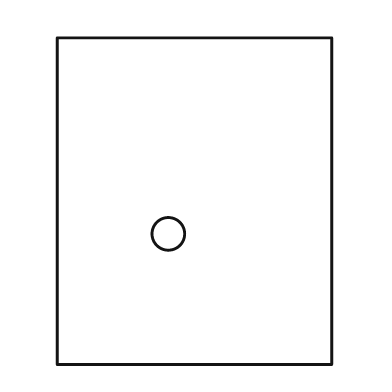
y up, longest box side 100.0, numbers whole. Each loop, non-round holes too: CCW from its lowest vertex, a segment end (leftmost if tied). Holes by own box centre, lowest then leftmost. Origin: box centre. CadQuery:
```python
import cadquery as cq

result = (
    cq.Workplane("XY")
    .moveTo(-42.0, -50.0)
    .lineTo(42.0, -50.0)
    .lineTo(42.0, 50.0)
    .lineTo(-42.0, 50.0)
    .close()
    .moveTo(-8.0, -10.0)
    .circle(5.0)
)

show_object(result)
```